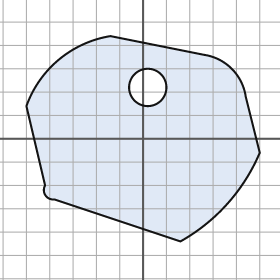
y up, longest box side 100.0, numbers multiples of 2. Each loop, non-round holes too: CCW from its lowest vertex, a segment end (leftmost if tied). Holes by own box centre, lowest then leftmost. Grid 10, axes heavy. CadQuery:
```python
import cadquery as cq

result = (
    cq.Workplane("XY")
    .moveTo(16.0, -44.0)
    .threePointArc((36.0, -28.0), (50.0, -6.0))
    .lineTo(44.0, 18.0)
    .threePointArc((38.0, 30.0), (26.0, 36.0))
    .lineTo(-14.0, 44.0)
    .threePointArc((-36.0, 34.0), (-50.0, 14.0))
    .lineTo(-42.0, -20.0)
    .threePointArc((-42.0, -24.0), (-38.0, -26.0))
    .close()
    .moveTo(2.0, 22.0)
    .circle(8.0)
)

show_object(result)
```